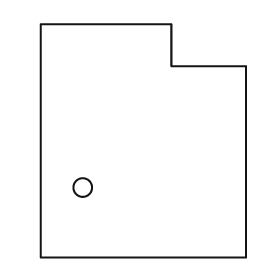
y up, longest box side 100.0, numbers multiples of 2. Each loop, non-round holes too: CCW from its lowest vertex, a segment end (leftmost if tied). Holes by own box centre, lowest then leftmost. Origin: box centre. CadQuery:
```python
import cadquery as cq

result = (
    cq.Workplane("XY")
    .moveTo(-44.0, -50.0)
    .lineTo(44.0, -50.0)
    .lineTo(44.0, 32.0)
    .lineTo(12.0, 32.0)
    .lineTo(12.0, 50.0)
    .lineTo(-44.0, 50.0)
    .close()
    .moveTo(-26.0, -20.0)
    .circle(4.0)
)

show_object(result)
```